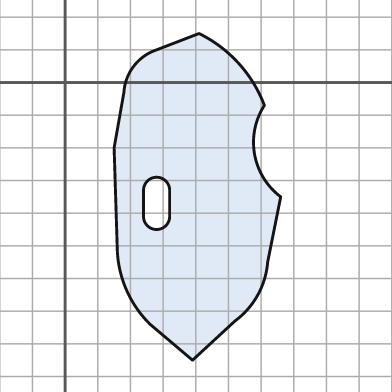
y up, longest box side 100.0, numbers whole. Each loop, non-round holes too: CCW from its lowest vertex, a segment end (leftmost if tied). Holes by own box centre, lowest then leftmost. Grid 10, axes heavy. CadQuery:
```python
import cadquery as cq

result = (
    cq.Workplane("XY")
    .moveTo(39.0, -85.0)
    .lineTo(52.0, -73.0)
    .threePointArc((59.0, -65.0), (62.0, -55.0))
    .lineTo(66.0, -35.0)
    .threePointArc((58.0, -22.0), (61.0, -7.0))
    .threePointArc((53.0, 6.0), (41.0, 15.0))
    .lineTo(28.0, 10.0)
    .threePointArc((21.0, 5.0), (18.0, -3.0))
    .lineTo(15.0, -20.0)
    .lineTo(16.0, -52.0)
    .threePointArc((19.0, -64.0), (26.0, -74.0))
    .close()
    .moveTo(24.0, -41.0)
    .threePointArc((28.0, -45.0), (32.0, -41.0))
    .lineTo(32.0, -33.0)
    .threePointArc((28.0, -29.0), (24.0, -33.0))
    .close()
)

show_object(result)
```